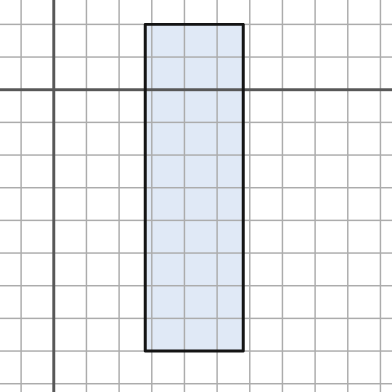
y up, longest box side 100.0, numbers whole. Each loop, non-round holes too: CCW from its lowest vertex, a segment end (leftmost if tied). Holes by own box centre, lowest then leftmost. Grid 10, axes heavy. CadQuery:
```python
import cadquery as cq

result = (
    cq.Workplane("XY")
    .moveTo(28.0, -80.0)
    .lineTo(58.0, -80.0)
    .lineTo(58.0, 20.0)
    .lineTo(28.0, 20.0)
    .close()
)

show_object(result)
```